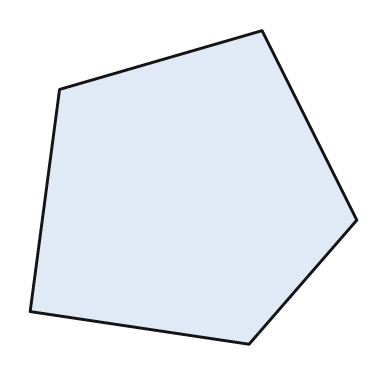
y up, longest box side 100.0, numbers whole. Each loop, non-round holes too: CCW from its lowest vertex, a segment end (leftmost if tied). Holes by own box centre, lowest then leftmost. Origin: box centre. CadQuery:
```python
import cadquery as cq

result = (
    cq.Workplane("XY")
    .moveTo(17.0, -48.0)
    .lineTo(50.0, -10.0)
    .lineTo(21.0, 48.0)
    .lineTo(-41.0, 30.0)
    .lineTo(-50.0, -38.0)
    .close()
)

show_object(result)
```